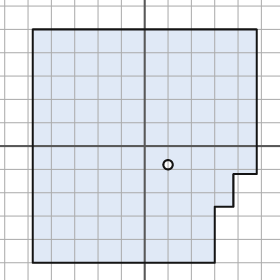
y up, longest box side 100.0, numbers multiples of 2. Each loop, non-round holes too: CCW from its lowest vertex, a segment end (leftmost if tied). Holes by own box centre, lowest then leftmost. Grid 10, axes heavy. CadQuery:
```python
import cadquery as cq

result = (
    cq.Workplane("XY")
    .moveTo(-48.0, -50.0)
    .lineTo(30.0, -50.0)
    .lineTo(30.0, -26.0)
    .lineTo(38.0, -26.0)
    .lineTo(38.0, -12.0)
    .lineTo(48.0, -12.0)
    .lineTo(48.0, 50.0)
    .lineTo(-48.0, 50.0)
    .close()
    .moveTo(10.0, -8.0)
    .circle(2.0)
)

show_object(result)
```